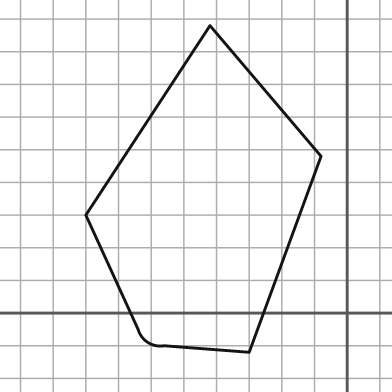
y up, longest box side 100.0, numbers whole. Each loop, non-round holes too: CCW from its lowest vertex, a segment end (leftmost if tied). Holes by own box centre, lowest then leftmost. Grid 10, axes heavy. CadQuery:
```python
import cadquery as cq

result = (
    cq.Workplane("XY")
    .moveTo(-30.0, -12.0)
    .lineTo(-8.0, 48.0)
    .lineTo(-42.0, 88.0)
    .lineTo(-80.0, 30.0)
    .lineTo(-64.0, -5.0)
    .threePointArc((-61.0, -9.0), (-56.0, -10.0))
    .close()
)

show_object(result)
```